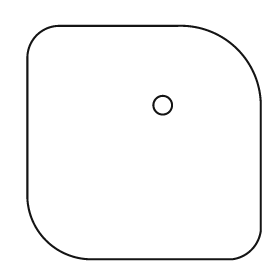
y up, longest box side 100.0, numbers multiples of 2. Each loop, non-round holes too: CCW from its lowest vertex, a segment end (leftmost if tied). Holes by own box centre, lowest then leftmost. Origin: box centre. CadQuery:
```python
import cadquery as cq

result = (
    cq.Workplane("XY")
    .moveTo(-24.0, -50.0)
    .lineTo(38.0, -50.0)
    .threePointArc((46.0, -46.0), (50.0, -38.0))
    .lineTo(50.0, 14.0)
    .threePointArc((40.0, 40.0), (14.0, 50.0))
    .lineTo(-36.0, 50.0)
    .threePointArc((-46.0, 46.0), (-50.0, 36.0))
    .lineTo(-50.0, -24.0)
    .threePointArc((-42.0, -42.0), (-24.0, -50.0))
    .close()
    .moveTo(8.0, 16.0)
    .circle(4.0)
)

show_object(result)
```